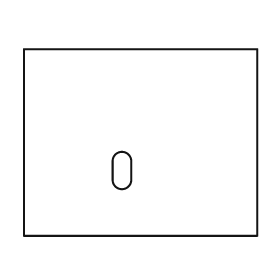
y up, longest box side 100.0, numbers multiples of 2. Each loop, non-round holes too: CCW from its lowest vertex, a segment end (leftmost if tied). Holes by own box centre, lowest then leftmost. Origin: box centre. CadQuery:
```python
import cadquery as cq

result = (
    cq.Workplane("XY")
    .moveTo(-50.0, -40.0)
    .lineTo(50.0, -40.0)
    .lineTo(50.0, 40.0)
    .lineTo(-50.0, 40.0)
    .close()
    .moveTo(-12.0, -16.0)
    .threePointArc((-8.0, -20.0), (-4.0, -16.0))
    .lineTo(-4.0, -8.0)
    .threePointArc((-8.0, -4.0), (-12.0, -8.0))
    .close()
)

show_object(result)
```